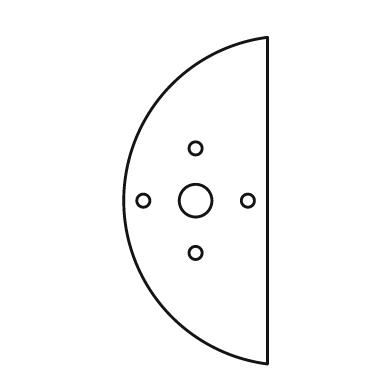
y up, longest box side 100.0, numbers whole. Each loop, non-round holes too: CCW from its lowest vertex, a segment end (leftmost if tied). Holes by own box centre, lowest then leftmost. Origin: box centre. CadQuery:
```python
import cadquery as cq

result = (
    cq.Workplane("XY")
    .moveTo(22.0, -50.0)
    .lineTo(22.0, 50.0)
    .threePointArc((-22.0, 0.0), (22.0, -50.0))
    .close()
    .moveTo(0.0, -16.0)
    .circle(2.0)
    .moveTo(-16.0, 0.0)
    .circle(2.0)
    .moveTo(0.0, 0.0)
    .circle(5.0)
    .moveTo(16.0, 0.0)
    .circle(2.0)
    .moveTo(0.0, 16.0)
    .circle(2.0)
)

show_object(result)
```